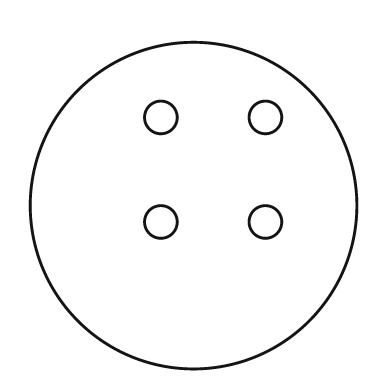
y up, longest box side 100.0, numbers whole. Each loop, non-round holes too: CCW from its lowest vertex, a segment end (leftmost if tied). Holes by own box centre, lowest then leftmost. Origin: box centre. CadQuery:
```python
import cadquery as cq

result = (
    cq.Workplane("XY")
    .moveTo(0.0, 0.0)
    .circle(50.0)
    .moveTo(-10.0, -5.0)
    .circle(5.0)
    .moveTo(22.0, -5.0)
    .circle(5.0)
    .moveTo(-10.0, 27.0)
    .circle(5.0)
    .moveTo(22.0, 27.0)
    .circle(5.0)
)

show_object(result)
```